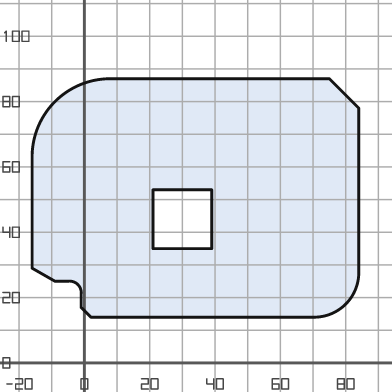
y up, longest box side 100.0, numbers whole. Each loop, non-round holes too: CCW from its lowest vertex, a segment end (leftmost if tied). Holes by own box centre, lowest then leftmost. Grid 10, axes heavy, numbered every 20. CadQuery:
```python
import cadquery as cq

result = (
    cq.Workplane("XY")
    .moveTo(2.0, 14.0)
    .lineTo(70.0, 14.0)
    .threePointArc((80.0, 18.0), (84.0, 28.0))
    .lineTo(84.0, 78.0)
    .lineTo(75.0, 87.0)
    .lineTo(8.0, 87.0)
    .threePointArc((-9.0, 80.0), (-16.0, 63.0))
    .lineTo(-16.0, 29.0)
    .lineTo(-9.0, 25.0)
    .lineTo(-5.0, 25.0)
    .threePointArc((-2.0, 24.0), (-1.0, 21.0))
    .lineTo(-1.0, 17.0)
    .close()
    .moveTo(21.0, 35.0)
    .lineTo(39.0, 35.0)
    .lineTo(39.0, 53.0)
    .lineTo(21.0, 53.0)
    .close()
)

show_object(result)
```